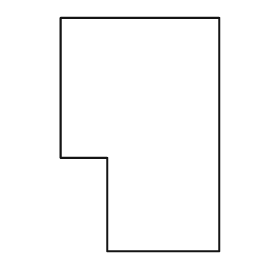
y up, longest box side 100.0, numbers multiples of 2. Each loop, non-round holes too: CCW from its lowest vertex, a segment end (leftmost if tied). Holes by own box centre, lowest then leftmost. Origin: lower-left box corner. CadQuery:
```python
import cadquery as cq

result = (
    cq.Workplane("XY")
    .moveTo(20.0, 0.0)
    .lineTo(68.0, 0.0)
    .lineTo(68.0, 100.0)
    .lineTo(0.0, 100.0)
    .lineTo(0.0, 40.0)
    .lineTo(20.0, 40.0)
    .close()
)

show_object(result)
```